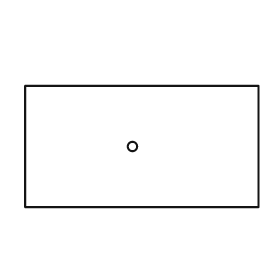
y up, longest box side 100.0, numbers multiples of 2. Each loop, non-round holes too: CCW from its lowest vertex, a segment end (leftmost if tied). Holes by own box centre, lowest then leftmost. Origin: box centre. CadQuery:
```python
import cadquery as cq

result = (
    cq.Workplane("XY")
    .moveTo(-50.0, -26.0)
    .lineTo(50.0, -26.0)
    .lineTo(50.0, 26.0)
    .lineTo(-50.0, 26.0)
    .close()
    .moveTo(-4.0, 0.0)
    .circle(2.0)
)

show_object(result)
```